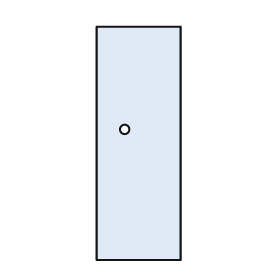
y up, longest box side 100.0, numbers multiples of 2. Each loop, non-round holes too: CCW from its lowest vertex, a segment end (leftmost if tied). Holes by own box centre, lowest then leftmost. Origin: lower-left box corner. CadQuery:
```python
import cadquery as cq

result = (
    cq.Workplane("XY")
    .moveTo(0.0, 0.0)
    .lineTo(36.0, 0.0)
    .lineTo(36.0, 100.0)
    .lineTo(0.0, 100.0)
    .close()
    .moveTo(12.0, 56.0)
    .circle(2.0)
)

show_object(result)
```